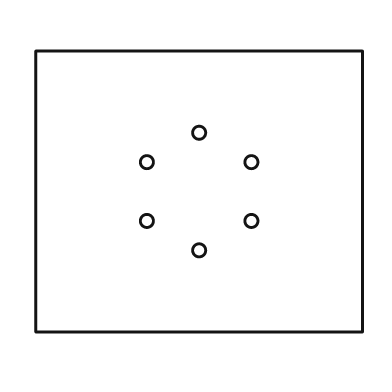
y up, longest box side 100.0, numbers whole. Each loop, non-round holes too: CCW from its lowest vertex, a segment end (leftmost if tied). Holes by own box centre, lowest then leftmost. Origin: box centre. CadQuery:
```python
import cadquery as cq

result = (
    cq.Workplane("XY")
    .moveTo(-50.0, -43.0)
    .lineTo(50.0, -43.0)
    .lineTo(50.0, 43.0)
    .lineTo(-50.0, 43.0)
    .close()
    .moveTo(0.0, -18.0)
    .circle(2.0)
    .moveTo(-16.0, -9.0)
    .circle(2.0)
    .moveTo(16.0, -9.0)
    .circle(2.0)
    .moveTo(-16.0, 9.0)
    .circle(2.0)
    .moveTo(16.0, 9.0)
    .circle(2.0)
    .moveTo(0.0, 18.0)
    .circle(2.0)
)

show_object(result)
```